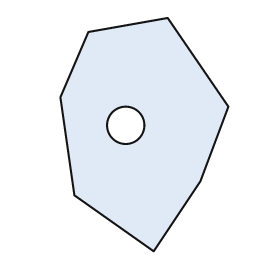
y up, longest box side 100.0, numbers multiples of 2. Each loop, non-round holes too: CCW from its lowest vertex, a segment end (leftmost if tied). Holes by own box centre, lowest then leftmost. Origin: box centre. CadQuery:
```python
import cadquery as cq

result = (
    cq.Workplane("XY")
    .moveTo(4.0, -50.0)
    .lineTo(24.0, -20.0)
    .lineTo(36.0, 12.0)
    .lineTo(10.0, 50.0)
    .lineTo(-24.0, 44.0)
    .lineTo(-36.0, 16.0)
    .lineTo(-30.0, -26.0)
    .close()
    .moveTo(-8.0, 4.0)
    .circle(8.0)
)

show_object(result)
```